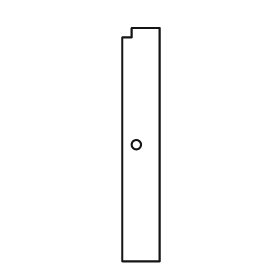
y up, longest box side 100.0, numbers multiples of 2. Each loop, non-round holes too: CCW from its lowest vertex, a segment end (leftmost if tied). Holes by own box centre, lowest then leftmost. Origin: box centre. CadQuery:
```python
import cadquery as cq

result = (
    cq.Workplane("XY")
    .moveTo(-8.0, -50.0)
    .lineTo(8.0, -50.0)
    .lineTo(8.0, 50.0)
    .lineTo(-4.0, 50.0)
    .lineTo(-4.0, 46.0)
    .lineTo(-8.0, 46.0)
    .close()
    .moveTo(-2.0, 0.0)
    .circle(2.0)
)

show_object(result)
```